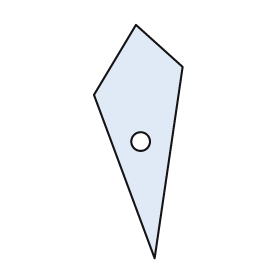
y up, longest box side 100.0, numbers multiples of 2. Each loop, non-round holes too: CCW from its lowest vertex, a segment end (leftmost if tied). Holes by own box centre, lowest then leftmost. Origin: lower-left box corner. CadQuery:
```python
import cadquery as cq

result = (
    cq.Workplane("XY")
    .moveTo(26.0, 0.0)
    .lineTo(38.0, 82.0)
    .lineTo(18.0, 100.0)
    .lineTo(0.0, 70.0)
    .close()
    .moveTo(20.0, 50.0)
    .circle(4.0)
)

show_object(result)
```